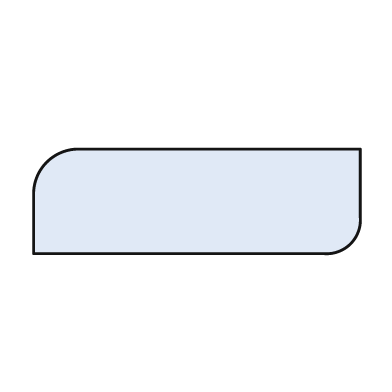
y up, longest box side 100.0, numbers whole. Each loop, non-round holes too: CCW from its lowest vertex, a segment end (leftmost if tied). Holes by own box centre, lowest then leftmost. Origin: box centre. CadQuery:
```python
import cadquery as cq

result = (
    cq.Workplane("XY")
    .moveTo(-50.0, -16.0)
    .lineTo(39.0, -16.0)
    .threePointArc((47.0, -13.0), (50.0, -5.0))
    .lineTo(50.0, 16.0)
    .lineTo(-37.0, 16.0)
    .threePointArc((-46.0, 12.0), (-50.0, 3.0))
    .close()
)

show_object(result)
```